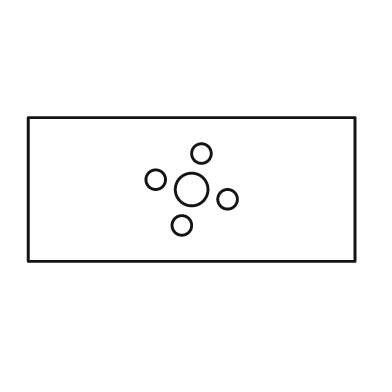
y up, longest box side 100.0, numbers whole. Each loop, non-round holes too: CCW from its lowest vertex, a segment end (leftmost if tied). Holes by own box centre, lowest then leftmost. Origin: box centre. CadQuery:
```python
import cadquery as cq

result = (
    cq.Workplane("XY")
    .moveTo(-50.0, -22.0)
    .lineTo(50.0, -22.0)
    .lineTo(50.0, 22.0)
    .lineTo(-50.0, 22.0)
    .close()
    .moveTo(-3.0, -11.0)
    .circle(3.0)
    .moveTo(11.0, -3.0)
    .circle(3.0)
    .moveTo(0.0, 0.0)
    .circle(5.0)
    .moveTo(-11.0, 3.0)
    .circle(3.0)
    .moveTo(3.0, 11.0)
    .circle(3.0)
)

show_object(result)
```